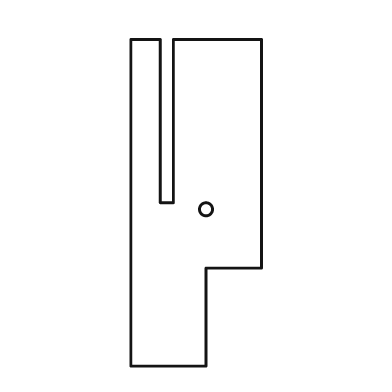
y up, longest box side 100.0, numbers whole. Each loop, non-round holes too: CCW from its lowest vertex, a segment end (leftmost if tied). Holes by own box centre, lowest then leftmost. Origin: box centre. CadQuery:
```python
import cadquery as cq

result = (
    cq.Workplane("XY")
    .moveTo(-20.0, -50.0)
    .lineTo(3.0, -50.0)
    .lineTo(3.0, -20.0)
    .lineTo(20.0, -20.0)
    .lineTo(20.0, 50.0)
    .lineTo(-7.0, 50.0)
    .lineTo(-7.0, 0.0)
    .lineTo(-11.0, 0.0)
    .lineTo(-11.0, 50.0)
    .lineTo(-20.0, 50.0)
    .close()
    .moveTo(3.0, -2.0)
    .circle(2.0)
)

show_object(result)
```